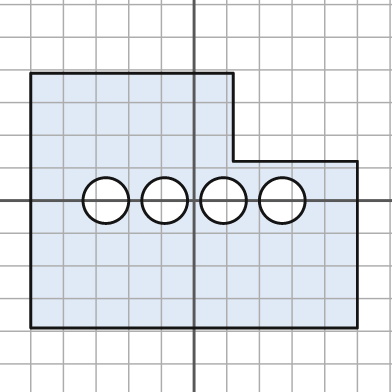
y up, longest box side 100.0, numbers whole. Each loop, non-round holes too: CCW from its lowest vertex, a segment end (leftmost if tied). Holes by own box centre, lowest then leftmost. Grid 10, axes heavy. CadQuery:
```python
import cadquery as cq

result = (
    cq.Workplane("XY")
    .moveTo(-50.0, -39.0)
    .lineTo(50.0, -39.0)
    .lineTo(50.0, 12.0)
    .lineTo(12.0, 12.0)
    .lineTo(12.0, 39.0)
    .lineTo(-50.0, 39.0)
    .close()
    .moveTo(-27.0, 0.0)
    .circle(7.0)
    .moveTo(-9.0, 0.0)
    .circle(7.0)
    .moveTo(9.0, 0.0)
    .circle(7.0)
    .moveTo(27.0, 0.0)
    .circle(7.0)
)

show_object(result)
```